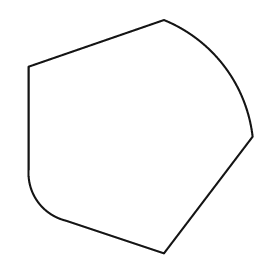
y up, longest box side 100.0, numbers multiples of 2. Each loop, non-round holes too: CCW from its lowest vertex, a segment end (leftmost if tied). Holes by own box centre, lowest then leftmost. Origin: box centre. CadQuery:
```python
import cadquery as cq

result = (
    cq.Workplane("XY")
    .moveTo(10.0, -50.0)
    .lineTo(48.0, 0.0)
    .threePointArc((36.0, 30.0), (10.0, 50.0))
    .lineTo(-48.0, 30.0)
    .lineTo(-48.0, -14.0)
    .threePointArc((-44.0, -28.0), (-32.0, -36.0))
    .close()
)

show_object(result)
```